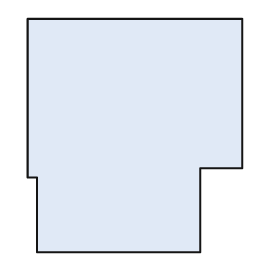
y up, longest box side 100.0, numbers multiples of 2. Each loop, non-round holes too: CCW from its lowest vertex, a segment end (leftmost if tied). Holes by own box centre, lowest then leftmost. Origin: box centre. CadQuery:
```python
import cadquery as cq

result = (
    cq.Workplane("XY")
    .moveTo(-42.0, -50.0)
    .lineTo(28.0, -50.0)
    .lineTo(28.0, -14.0)
    .lineTo(46.0, -14.0)
    .lineTo(46.0, 50.0)
    .lineTo(-46.0, 50.0)
    .lineTo(-46.0, -18.0)
    .lineTo(-42.0, -18.0)
    .close()
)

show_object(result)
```